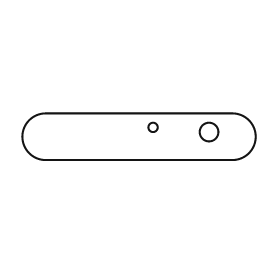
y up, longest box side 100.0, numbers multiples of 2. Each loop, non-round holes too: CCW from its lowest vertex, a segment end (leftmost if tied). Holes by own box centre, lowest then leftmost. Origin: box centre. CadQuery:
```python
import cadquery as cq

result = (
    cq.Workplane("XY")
    .moveTo(-40.0, -10.0)
    .lineTo(40.0, -10.0)
    .threePointArc((50.0, 0.0), (40.0, 10.0))
    .lineTo(-40.0, 10.0)
    .threePointArc((-50.0, 0.0), (-40.0, -10.0))
    .close()
    .moveTo(30.0, 2.0)
    .circle(4.0)
    .moveTo(6.0, 4.0)
    .circle(2.0)
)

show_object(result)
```